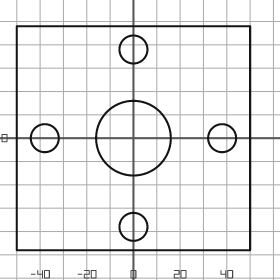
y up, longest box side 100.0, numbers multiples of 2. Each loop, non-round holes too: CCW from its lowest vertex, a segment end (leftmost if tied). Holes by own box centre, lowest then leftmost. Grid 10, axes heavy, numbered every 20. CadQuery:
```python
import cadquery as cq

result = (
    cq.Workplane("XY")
    .moveTo(-50.0, -48.0)
    .lineTo(50.0, -48.0)
    .lineTo(50.0, 48.0)
    .lineTo(-50.0, 48.0)
    .close()
    .moveTo(0.0, -38.0)
    .circle(6.0)
    .moveTo(-38.0, 0.0)
    .circle(6.0)
    .moveTo(0.0, 0.0)
    .circle(16.0)
    .moveTo(38.0, 0.0)
    .circle(6.0)
    .moveTo(0.0, 38.0)
    .circle(6.0)
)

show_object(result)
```